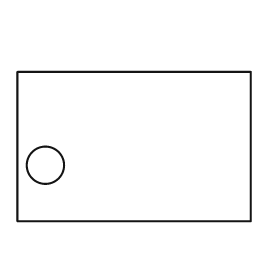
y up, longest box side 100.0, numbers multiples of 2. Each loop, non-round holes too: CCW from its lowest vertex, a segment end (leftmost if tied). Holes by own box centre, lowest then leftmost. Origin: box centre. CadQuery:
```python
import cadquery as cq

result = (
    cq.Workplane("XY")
    .moveTo(-50.0, -32.0)
    .lineTo(50.0, -32.0)
    .lineTo(50.0, 32.0)
    .lineTo(-50.0, 32.0)
    .close()
    .moveTo(-38.0, -8.0)
    .circle(8.0)
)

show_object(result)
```